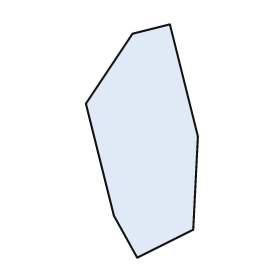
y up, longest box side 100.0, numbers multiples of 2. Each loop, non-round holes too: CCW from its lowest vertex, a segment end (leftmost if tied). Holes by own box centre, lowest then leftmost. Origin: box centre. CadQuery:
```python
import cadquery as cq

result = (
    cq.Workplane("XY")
    .moveTo(-2.0, -50.0)
    .lineTo(22.0, -38.0)
    .lineTo(24.0, 2.0)
    .lineTo(12.0, 50.0)
    .lineTo(-4.0, 46.0)
    .lineTo(-24.0, 16.0)
    .lineTo(-12.0, -32.0)
    .close()
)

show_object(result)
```